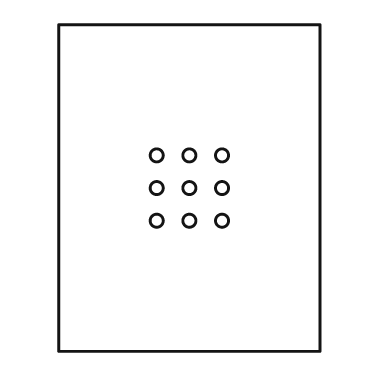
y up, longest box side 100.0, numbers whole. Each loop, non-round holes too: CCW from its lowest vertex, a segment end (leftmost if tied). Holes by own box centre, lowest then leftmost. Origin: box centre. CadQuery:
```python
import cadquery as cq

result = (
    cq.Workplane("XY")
    .moveTo(-40.0, -50.0)
    .lineTo(40.0, -50.0)
    .lineTo(40.0, 50.0)
    .lineTo(-40.0, 50.0)
    .close()
    .moveTo(-10.0, -10.0)
    .circle(2.0)
    .moveTo(0.0, -10.0)
    .circle(2.0)
    .moveTo(10.0, -10.0)
    .circle(2.0)
    .moveTo(-10.0, 0.0)
    .circle(2.0)
    .moveTo(0.0, 0.0)
    .circle(2.0)
    .moveTo(10.0, 0.0)
    .circle(2.0)
    .moveTo(-10.0, 10.0)
    .circle(2.0)
    .moveTo(0.0, 10.0)
    .circle(2.0)
    .moveTo(10.0, 10.0)
    .circle(2.0)
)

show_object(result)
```